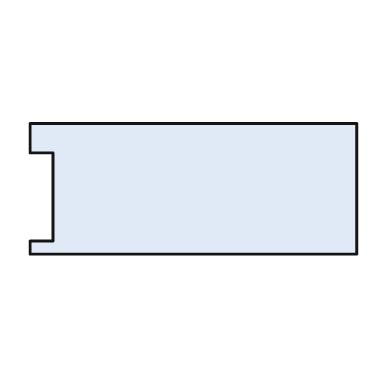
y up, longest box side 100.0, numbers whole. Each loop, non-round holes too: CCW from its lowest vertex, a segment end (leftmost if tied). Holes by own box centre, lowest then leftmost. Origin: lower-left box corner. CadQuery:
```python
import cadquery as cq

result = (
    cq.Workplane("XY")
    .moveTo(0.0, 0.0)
    .lineTo(100.0, 0.0)
    .lineTo(100.0, 40.0)
    .lineTo(0.0, 40.0)
    .lineTo(0.0, 31.0)
    .lineTo(7.0, 31.0)
    .lineTo(7.0, 4.0)
    .lineTo(0.0, 4.0)
    .close()
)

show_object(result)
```